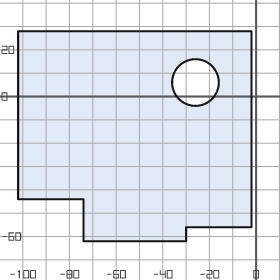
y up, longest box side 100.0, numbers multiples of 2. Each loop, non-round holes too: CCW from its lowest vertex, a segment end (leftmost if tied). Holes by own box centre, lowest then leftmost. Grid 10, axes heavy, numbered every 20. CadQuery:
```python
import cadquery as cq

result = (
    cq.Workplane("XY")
    .moveTo(-74.0, -62.0)
    .lineTo(-30.0, -62.0)
    .lineTo(-30.0, -56.0)
    .lineTo(-2.0, -56.0)
    .lineTo(-2.0, 28.0)
    .lineTo(-102.0, 28.0)
    .lineTo(-102.0, -44.0)
    .lineTo(-74.0, -44.0)
    .close()
    .moveTo(-26.0, 6.0)
    .circle(10.0)
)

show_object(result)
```